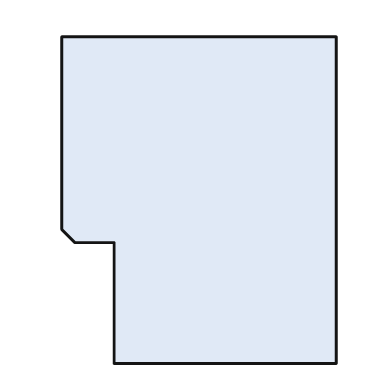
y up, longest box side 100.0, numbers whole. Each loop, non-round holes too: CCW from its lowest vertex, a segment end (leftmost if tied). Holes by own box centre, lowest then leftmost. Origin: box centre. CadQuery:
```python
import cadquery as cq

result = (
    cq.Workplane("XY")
    .moveTo(-26.0, -50.0)
    .lineTo(42.0, -50.0)
    .lineTo(42.0, 50.0)
    .lineTo(-42.0, 50.0)
    .lineTo(-42.0, -9.0)
    .lineTo(-38.0, -13.0)
    .lineTo(-26.0, -13.0)
    .close()
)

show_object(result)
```